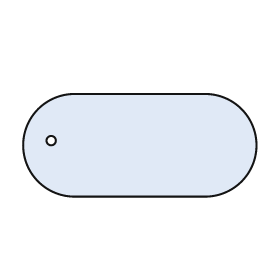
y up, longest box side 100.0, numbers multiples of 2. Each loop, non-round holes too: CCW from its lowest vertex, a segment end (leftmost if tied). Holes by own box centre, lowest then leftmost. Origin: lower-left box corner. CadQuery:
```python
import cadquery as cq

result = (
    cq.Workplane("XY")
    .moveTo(22.0, 0.0)
    .lineTo(78.0, 0.0)
    .threePointArc((100.0, 22.0), (78.0, 44.0))
    .lineTo(22.0, 44.0)
    .threePointArc((0.0, 22.0), (22.0, 0.0))
    .close()
    .moveTo(12.0, 24.0)
    .circle(2.0)
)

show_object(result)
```